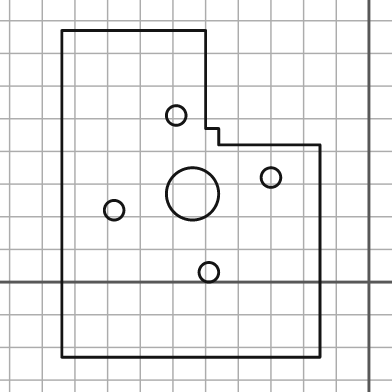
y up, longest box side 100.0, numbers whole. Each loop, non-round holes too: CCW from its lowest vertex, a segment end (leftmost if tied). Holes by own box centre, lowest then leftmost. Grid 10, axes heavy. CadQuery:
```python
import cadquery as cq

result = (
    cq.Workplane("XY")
    .moveTo(-94.0, -23.0)
    .lineTo(-15.0, -23.0)
    .lineTo(-15.0, 42.0)
    .lineTo(-46.0, 42.0)
    .lineTo(-46.0, 47.0)
    .lineTo(-50.0, 47.0)
    .lineTo(-50.0, 77.0)
    .lineTo(-94.0, 77.0)
    .close()
    .moveTo(-49.0, 3.0)
    .circle(3.0)
    .moveTo(-78.0, 22.0)
    .circle(3.0)
    .moveTo(-54.0, 27.0)
    .circle(8.0)
    .moveTo(-30.0, 32.0)
    .circle(3.0)
    .moveTo(-59.0, 51.0)
    .circle(3.0)
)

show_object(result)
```